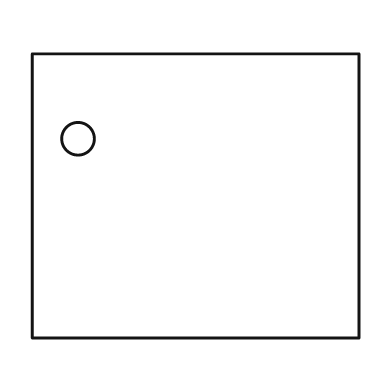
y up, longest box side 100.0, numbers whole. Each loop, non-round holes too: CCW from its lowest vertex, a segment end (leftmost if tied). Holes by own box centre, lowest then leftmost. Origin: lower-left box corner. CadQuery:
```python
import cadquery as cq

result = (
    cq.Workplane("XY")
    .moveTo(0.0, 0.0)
    .lineTo(100.0, 0.0)
    .lineTo(100.0, 87.0)
    .lineTo(0.0, 87.0)
    .close()
    .moveTo(14.0, 61.0)
    .circle(5.0)
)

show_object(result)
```